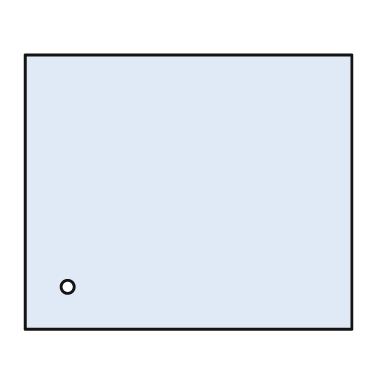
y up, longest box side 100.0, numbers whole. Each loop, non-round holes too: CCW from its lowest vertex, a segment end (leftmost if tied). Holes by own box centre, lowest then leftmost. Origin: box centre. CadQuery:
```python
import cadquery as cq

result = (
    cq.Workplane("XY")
    .moveTo(-50.0, -42.0)
    .lineTo(50.0, -42.0)
    .lineTo(50.0, 42.0)
    .lineTo(-50.0, 42.0)
    .close()
    .moveTo(-37.0, -29.0)
    .circle(2.0)
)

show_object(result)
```